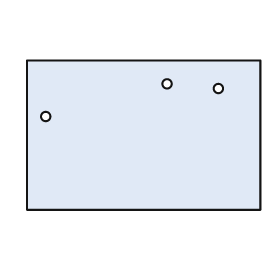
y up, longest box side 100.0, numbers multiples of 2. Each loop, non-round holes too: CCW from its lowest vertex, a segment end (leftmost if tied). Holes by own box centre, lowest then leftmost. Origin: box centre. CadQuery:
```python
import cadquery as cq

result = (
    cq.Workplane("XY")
    .moveTo(-50.0, -32.0)
    .lineTo(50.0, -32.0)
    .lineTo(50.0, 32.0)
    .lineTo(-50.0, 32.0)
    .close()
    .moveTo(-42.0, 8.0)
    .circle(2.0)
    .moveTo(32.0, 20.0)
    .circle(2.0)
    .moveTo(10.0, 22.0)
    .circle(2.0)
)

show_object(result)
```